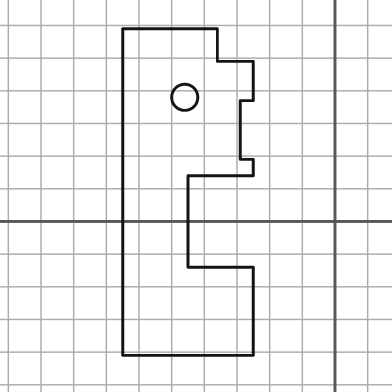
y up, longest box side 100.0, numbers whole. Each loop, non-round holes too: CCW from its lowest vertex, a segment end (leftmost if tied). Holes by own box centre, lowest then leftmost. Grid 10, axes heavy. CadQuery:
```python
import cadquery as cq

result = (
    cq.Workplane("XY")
    .moveTo(-65.0, -41.0)
    .lineTo(-25.0, -41.0)
    .lineTo(-25.0, -14.0)
    .lineTo(-45.0, -14.0)
    .lineTo(-45.0, 14.0)
    .lineTo(-25.0, 14.0)
    .lineTo(-25.0, 19.0)
    .lineTo(-29.0, 19.0)
    .lineTo(-29.0, 37.0)
    .lineTo(-25.0, 37.0)
    .lineTo(-25.0, 49.0)
    .lineTo(-36.0, 49.0)
    .lineTo(-36.0, 59.0)
    .lineTo(-65.0, 59.0)
    .close()
    .moveTo(-46.0, 38.0)
    .circle(4.0)
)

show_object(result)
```